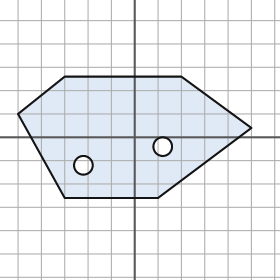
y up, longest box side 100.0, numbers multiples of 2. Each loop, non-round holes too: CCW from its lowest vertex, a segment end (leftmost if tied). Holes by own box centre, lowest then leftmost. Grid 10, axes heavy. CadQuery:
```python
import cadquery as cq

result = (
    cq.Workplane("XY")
    .moveTo(-30.0, -26.0)
    .lineTo(10.0, -26.0)
    .lineTo(50.0, 4.0)
    .lineTo(20.0, 26.0)
    .lineTo(-30.0, 26.0)
    .lineTo(-50.0, 10.0)
    .close()
    .moveTo(-22.0, -12.0)
    .circle(4.0)
    .moveTo(12.0, -4.0)
    .circle(4.0)
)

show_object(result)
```